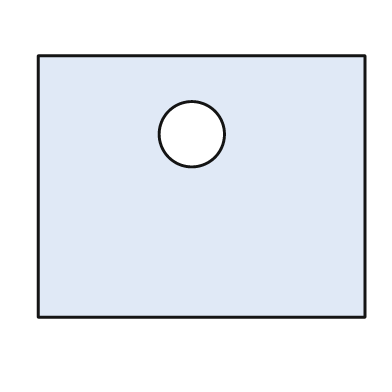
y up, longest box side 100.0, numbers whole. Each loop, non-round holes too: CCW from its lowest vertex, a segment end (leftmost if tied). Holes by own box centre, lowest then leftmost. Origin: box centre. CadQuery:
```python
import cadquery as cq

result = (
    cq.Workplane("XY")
    .moveTo(-50.0, -40.0)
    .lineTo(50.0, -40.0)
    .lineTo(50.0, 40.0)
    .lineTo(-50.0, 40.0)
    .close()
    .moveTo(-3.0, 16.0)
    .circle(10.0)
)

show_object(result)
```